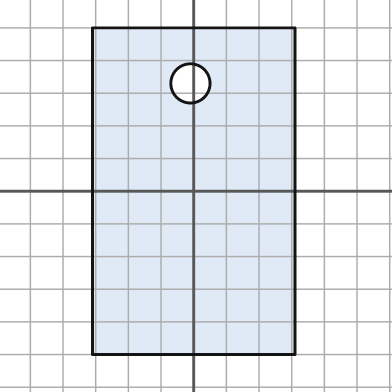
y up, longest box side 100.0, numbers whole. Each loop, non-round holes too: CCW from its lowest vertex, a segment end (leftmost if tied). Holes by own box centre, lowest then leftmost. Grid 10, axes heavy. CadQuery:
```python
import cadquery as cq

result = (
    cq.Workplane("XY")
    .moveTo(-31.0, -50.0)
    .lineTo(31.0, -50.0)
    .lineTo(31.0, 50.0)
    .lineTo(-31.0, 50.0)
    .close()
    .moveTo(-1.0, 33.0)
    .circle(6.0)
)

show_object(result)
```